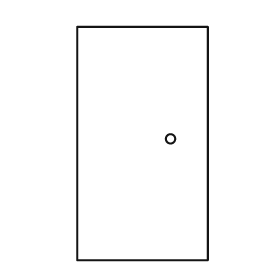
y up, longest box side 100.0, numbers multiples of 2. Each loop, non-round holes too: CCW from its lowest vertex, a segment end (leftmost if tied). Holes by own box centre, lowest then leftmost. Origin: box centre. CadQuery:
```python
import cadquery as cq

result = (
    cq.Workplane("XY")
    .moveTo(-28.0, -50.0)
    .lineTo(28.0, -50.0)
    .lineTo(28.0, 50.0)
    .lineTo(-28.0, 50.0)
    .close()
    .moveTo(12.0, 2.0)
    .circle(2.0)
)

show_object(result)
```